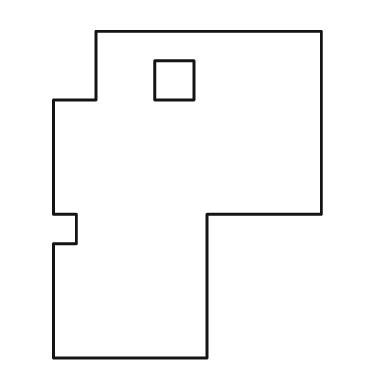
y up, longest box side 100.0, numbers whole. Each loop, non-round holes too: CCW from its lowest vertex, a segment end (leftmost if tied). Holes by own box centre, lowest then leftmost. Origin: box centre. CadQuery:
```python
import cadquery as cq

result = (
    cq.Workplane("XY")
    .moveTo(-41.0, -50.0)
    .lineTo(6.0, -50.0)
    .lineTo(6.0, -6.0)
    .lineTo(41.0, -6.0)
    .lineTo(41.0, 50.0)
    .lineTo(-28.0, 50.0)
    .lineTo(-28.0, 29.0)
    .lineTo(-41.0, 29.0)
    .lineTo(-41.0, -6.0)
    .lineTo(-34.0, -6.0)
    .lineTo(-34.0, -15.0)
    .lineTo(-41.0, -15.0)
    .close()
    .moveTo(-10.0, 29.0)
    .lineTo(2.0, 29.0)
    .lineTo(2.0, 41.0)
    .lineTo(-10.0, 41.0)
    .close()
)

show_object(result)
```